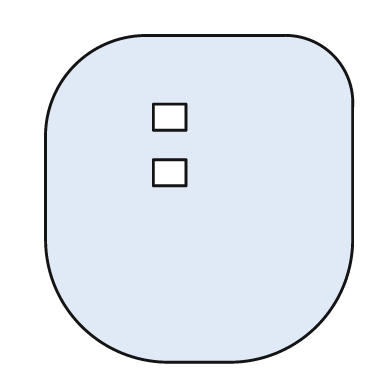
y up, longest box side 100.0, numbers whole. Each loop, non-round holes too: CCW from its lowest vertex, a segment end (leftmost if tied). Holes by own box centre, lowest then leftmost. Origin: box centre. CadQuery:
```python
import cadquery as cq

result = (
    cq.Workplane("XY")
    .moveTo(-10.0, -50.0)
    .lineTo(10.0, -50.0)
    .threePointArc((36.0, -39.0), (47.0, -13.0))
    .lineTo(47.0, 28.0)
    .threePointArc((41.0, 44.0), (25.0, 50.0))
    .lineTo(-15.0, 50.0)
    .threePointArc((-38.0, 41.0), (-47.0, 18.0))
    .lineTo(-47.0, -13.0)
    .threePointArc((-36.0, -39.0), (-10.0, -50.0))
    .close()
    .moveTo(-14.0, 4.0)
    .lineTo(-4.0, 4.0)
    .lineTo(-4.0, 12.0)
    .lineTo(-14.0, 12.0)
    .close()
    .moveTo(-14.0, 21.0)
    .lineTo(-4.0, 21.0)
    .lineTo(-4.0, 29.0)
    .lineTo(-14.0, 29.0)
    .close()
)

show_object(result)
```